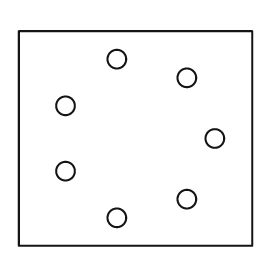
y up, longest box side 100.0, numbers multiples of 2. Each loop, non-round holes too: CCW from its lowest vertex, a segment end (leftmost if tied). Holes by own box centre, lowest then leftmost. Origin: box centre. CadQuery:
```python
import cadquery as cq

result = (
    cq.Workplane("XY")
    .moveTo(-50.0, -46.0)
    .lineTo(50.0, -46.0)
    .lineTo(50.0, 46.0)
    .lineTo(-50.0, 46.0)
    .close()
    .moveTo(-8.0, -34.0)
    .circle(4.0)
    .moveTo(22.0, -26.0)
    .circle(4.0)
    .moveTo(-30.0, -14.0)
    .circle(4.0)
    .moveTo(34.0, 0.0)
    .circle(4.0)
    .moveTo(-30.0, 14.0)
    .circle(4.0)
    .moveTo(22.0, 26.0)
    .circle(4.0)
    .moveTo(-8.0, 34.0)
    .circle(4.0)
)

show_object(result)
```